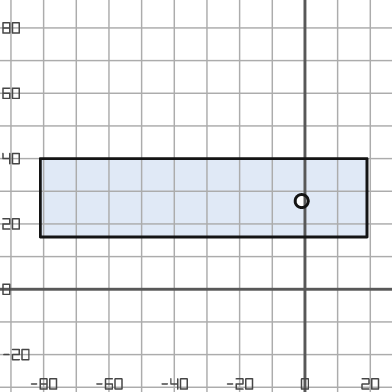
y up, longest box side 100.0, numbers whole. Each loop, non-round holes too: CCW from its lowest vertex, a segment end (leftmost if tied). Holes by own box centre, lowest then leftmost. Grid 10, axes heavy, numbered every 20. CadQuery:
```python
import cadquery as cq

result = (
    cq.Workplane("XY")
    .moveTo(-81.0, 16.0)
    .lineTo(19.0, 16.0)
    .lineTo(19.0, 40.0)
    .lineTo(-81.0, 40.0)
    .close()
    .moveTo(-1.0, 27.0)
    .circle(2.0)
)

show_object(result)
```